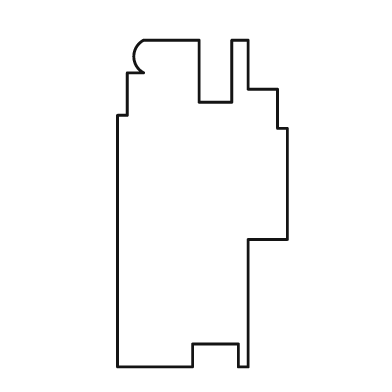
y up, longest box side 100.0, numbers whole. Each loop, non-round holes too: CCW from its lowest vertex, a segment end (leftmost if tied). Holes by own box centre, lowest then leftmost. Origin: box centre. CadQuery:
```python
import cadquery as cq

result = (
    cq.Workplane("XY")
    .moveTo(-26.0, -50.0)
    .lineTo(-3.0, -50.0)
    .lineTo(-3.0, -43.0)
    .lineTo(11.0, -43.0)
    .lineTo(11.0, -50.0)
    .lineTo(14.0, -50.0)
    .lineTo(14.0, -11.0)
    .lineTo(26.0, -11.0)
    .lineTo(26.0, 23.0)
    .lineTo(23.0, 23.0)
    .lineTo(23.0, 35.0)
    .lineTo(14.0, 35.0)
    .lineTo(14.0, 50.0)
    .lineTo(9.0, 50.0)
    .lineTo(9.0, 31.0)
    .lineTo(-1.0, 31.0)
    .lineTo(-1.0, 50.0)
    .lineTo(-18.0, 50.0)
    .threePointArc((-21.0, 45.0), (-18.0, 40.0))
    .lineTo(-23.0, 40.0)
    .lineTo(-23.0, 27.0)
    .lineTo(-26.0, 27.0)
    .close()
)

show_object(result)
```